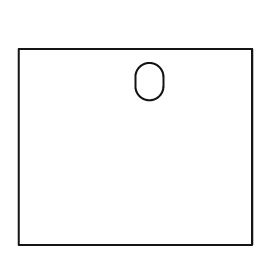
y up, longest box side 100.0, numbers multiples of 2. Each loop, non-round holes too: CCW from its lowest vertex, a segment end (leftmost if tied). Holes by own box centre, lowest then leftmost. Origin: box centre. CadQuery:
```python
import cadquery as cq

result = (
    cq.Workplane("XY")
    .moveTo(-50.0, -42.0)
    .lineTo(50.0, -42.0)
    .lineTo(50.0, 42.0)
    .lineTo(-50.0, 42.0)
    .close()
    .moveTo(0.0, 26.0)
    .threePointArc((6.0, 20.0), (12.0, 26.0))
    .lineTo(12.0, 30.0)
    .threePointArc((6.0, 36.0), (0.0, 30.0))
    .close()
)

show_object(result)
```